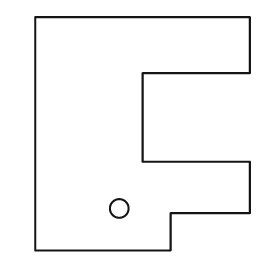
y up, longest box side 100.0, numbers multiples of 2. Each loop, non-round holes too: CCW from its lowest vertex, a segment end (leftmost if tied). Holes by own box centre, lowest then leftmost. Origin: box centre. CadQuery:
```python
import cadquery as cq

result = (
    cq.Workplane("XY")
    .moveTo(-46.0, -50.0)
    .lineTo(12.0, -50.0)
    .lineTo(12.0, -34.0)
    .lineTo(46.0, -34.0)
    .lineTo(46.0, -12.0)
    .lineTo(0.0, -12.0)
    .lineTo(0.0, 26.0)
    .lineTo(46.0, 26.0)
    .lineTo(46.0, 50.0)
    .lineTo(-46.0, 50.0)
    .close()
    .moveTo(-10.0, -32.0)
    .circle(4.0)
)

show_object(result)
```